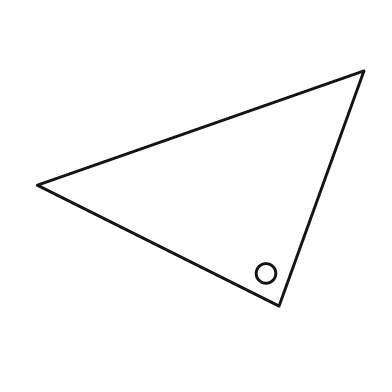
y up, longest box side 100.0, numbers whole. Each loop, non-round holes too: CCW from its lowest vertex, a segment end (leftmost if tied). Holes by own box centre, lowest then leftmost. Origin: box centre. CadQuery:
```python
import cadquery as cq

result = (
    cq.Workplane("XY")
    .moveTo(24.0, -36.0)
    .lineTo(50.0, 36.0)
    .lineTo(-50.0, 1.0)
    .close()
    .moveTo(20.0, -26.0)
    .circle(3.0)
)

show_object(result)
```